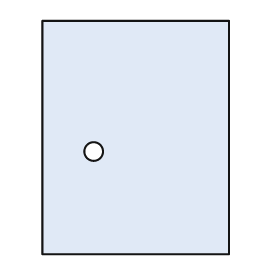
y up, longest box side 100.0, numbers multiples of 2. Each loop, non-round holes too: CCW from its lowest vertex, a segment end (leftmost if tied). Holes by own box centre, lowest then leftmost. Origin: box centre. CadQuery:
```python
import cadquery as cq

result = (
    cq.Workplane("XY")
    .moveTo(-40.0, -50.0)
    .lineTo(40.0, -50.0)
    .lineTo(40.0, 50.0)
    .lineTo(-40.0, 50.0)
    .close()
    .moveTo(-18.0, -6.0)
    .circle(4.0)
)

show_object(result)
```